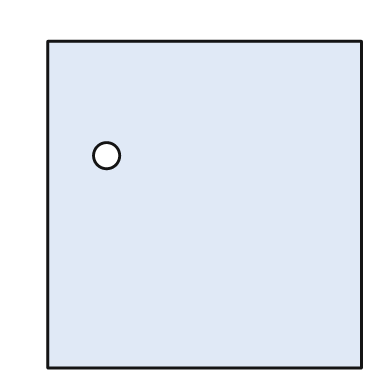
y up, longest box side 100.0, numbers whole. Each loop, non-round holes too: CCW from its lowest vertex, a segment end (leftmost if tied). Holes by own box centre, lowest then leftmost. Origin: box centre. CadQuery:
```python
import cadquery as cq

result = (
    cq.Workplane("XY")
    .moveTo(-48.0, -50.0)
    .lineTo(48.0, -50.0)
    .lineTo(48.0, 50.0)
    .lineTo(-48.0, 50.0)
    .close()
    .moveTo(-30.0, 15.0)
    .circle(4.0)
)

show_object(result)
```